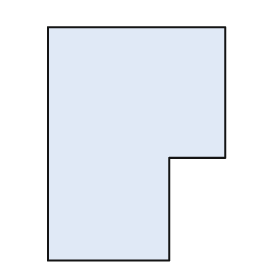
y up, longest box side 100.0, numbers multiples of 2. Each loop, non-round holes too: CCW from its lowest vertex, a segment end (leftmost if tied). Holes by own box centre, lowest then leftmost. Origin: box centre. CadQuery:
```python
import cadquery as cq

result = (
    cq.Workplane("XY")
    .moveTo(-38.0, -50.0)
    .lineTo(14.0, -50.0)
    .lineTo(14.0, -6.0)
    .lineTo(38.0, -6.0)
    .lineTo(38.0, 50.0)
    .lineTo(-38.0, 50.0)
    .close()
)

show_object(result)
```